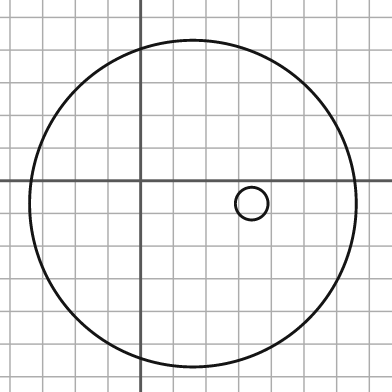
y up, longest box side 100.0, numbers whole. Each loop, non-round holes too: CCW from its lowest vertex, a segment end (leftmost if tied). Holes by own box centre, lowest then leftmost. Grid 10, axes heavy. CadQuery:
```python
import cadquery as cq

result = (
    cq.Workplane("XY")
    .moveTo(16.0, -7.0)
    .circle(50.0)
    .moveTo(34.0, -7.0)
    .circle(5.0)
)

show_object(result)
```